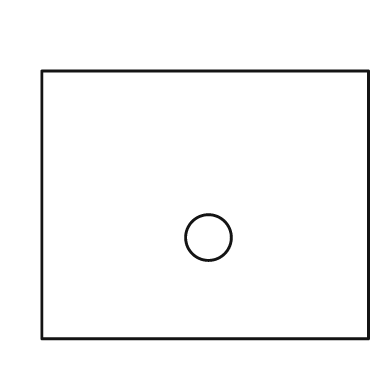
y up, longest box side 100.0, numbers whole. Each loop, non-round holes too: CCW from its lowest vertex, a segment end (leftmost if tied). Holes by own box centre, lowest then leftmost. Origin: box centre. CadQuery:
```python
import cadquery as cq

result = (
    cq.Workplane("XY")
    .moveTo(-50.0, -41.0)
    .lineTo(50.0, -41.0)
    .lineTo(50.0, 41.0)
    .lineTo(-50.0, 41.0)
    .close()
    .moveTo(1.0, -10.0)
    .circle(7.0)
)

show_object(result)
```